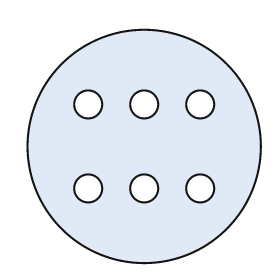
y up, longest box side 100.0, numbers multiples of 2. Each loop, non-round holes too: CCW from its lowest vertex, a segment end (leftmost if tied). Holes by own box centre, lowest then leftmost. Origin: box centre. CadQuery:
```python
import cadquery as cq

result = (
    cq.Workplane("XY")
    .moveTo(0.0, 0.0)
    .circle(50.0)
    .moveTo(-24.0, -18.0)
    .circle(6.0)
    .moveTo(0.0, -18.0)
    .circle(6.0)
    .moveTo(24.0, -18.0)
    .circle(6.0)
    .moveTo(-24.0, 18.0)
    .circle(6.0)
    .moveTo(0.0, 18.0)
    .circle(6.0)
    .moveTo(24.0, 18.0)
    .circle(6.0)
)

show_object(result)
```